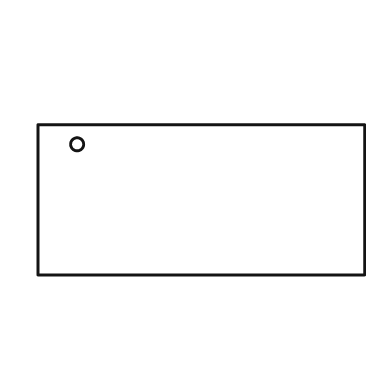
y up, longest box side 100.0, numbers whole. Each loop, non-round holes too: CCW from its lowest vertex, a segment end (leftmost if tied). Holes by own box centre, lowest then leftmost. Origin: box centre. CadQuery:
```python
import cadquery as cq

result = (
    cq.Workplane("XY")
    .moveTo(-50.0, -23.0)
    .lineTo(50.0, -23.0)
    .lineTo(50.0, 23.0)
    .lineTo(-50.0, 23.0)
    .close()
    .moveTo(-38.0, 17.0)
    .circle(2.0)
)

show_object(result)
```